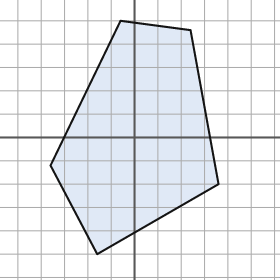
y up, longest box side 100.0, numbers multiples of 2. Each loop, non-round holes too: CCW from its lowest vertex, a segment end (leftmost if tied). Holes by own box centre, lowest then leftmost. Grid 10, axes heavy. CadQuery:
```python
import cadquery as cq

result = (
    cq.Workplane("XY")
    .moveTo(-16.0, -50.0)
    .lineTo(36.0, -20.0)
    .lineTo(24.0, 46.0)
    .lineTo(-6.0, 50.0)
    .lineTo(-36.0, -12.0)
    .close()
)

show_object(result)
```